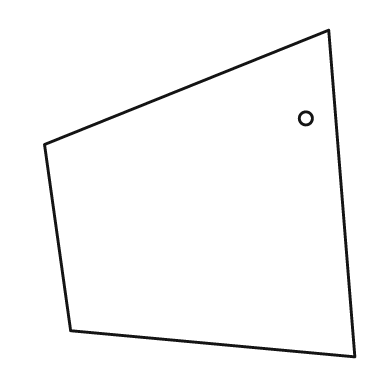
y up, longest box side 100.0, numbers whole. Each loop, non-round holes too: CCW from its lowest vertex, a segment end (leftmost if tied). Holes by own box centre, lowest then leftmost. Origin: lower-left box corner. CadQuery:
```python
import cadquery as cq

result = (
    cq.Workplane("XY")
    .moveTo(95.0, 0.0)
    .lineTo(87.0, 100.0)
    .lineTo(0.0, 65.0)
    .lineTo(8.0, 8.0)
    .close()
    .moveTo(80.0, 73.0)
    .circle(2.0)
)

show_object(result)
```